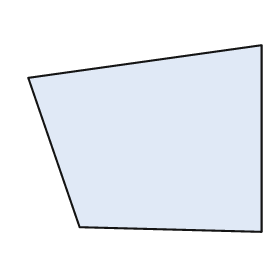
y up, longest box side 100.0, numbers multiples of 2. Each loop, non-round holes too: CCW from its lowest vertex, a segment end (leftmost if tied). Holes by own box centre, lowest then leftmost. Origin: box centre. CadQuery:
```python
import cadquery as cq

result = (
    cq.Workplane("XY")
    .moveTo(50.0, -40.0)
    .lineTo(50.0, 40.0)
    .lineTo(-50.0, 26.0)
    .lineTo(-28.0, -38.0)
    .close()
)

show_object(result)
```